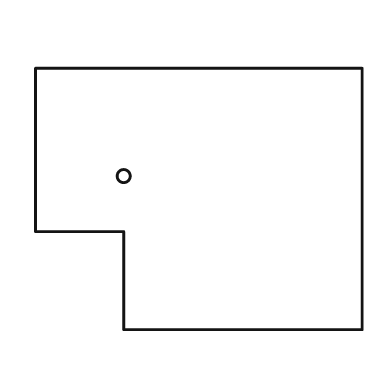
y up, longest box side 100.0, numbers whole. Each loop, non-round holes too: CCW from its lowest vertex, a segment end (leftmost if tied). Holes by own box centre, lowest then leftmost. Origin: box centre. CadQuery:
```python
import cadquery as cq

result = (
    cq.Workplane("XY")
    .moveTo(-23.0, -40.0)
    .lineTo(50.0, -40.0)
    .lineTo(50.0, 40.0)
    .lineTo(-50.0, 40.0)
    .lineTo(-50.0, -10.0)
    .lineTo(-23.0, -10.0)
    .close()
    .moveTo(-23.0, 7.0)
    .circle(2.0)
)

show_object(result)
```